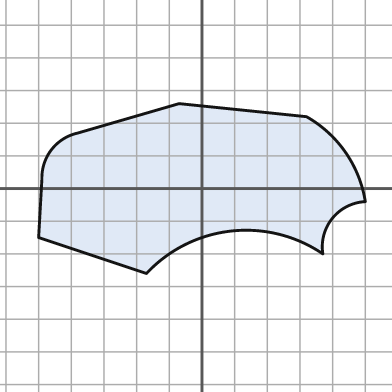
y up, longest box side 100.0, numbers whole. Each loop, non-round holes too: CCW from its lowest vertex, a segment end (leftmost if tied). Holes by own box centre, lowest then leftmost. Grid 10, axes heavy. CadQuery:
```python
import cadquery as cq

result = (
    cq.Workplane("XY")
    .moveTo(-17.0, -26.0)
    .threePointArc((9.0, -13.0), (37.0, -20.0))
    .threePointArc((40.0, -9.0), (50.0, -4.0))
    .threePointArc((44.0, 11.0), (32.0, 22.0))
    .lineTo(-7.0, 26.0)
    .lineTo(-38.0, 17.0)
    .threePointArc((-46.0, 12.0), (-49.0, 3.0))
    .lineTo(-50.0, -15.0)
    .close()
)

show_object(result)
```